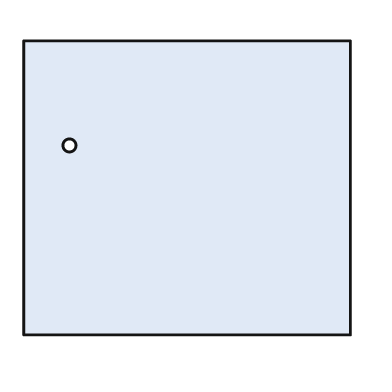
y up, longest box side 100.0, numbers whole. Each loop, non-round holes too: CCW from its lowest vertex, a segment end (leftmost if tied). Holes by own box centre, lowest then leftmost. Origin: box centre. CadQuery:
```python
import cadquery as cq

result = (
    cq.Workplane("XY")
    .moveTo(-50.0, -45.0)
    .lineTo(50.0, -45.0)
    .lineTo(50.0, 45.0)
    .lineTo(-50.0, 45.0)
    .close()
    .moveTo(-36.0, 13.0)
    .circle(2.0)
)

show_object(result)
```